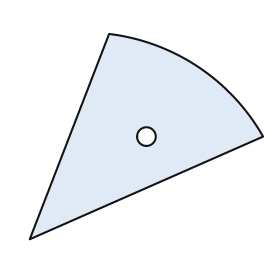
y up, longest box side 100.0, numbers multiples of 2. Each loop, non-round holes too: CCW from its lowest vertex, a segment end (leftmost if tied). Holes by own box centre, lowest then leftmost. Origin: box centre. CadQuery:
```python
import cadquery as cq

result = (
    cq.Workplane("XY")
    .moveTo(-50.0, -44.0)
    .lineTo(50.0, 0.0)
    .threePointArc((22.0, 30.0), (-16.0, 44.0))
    .close()
    .moveTo(0.0, 0.0)
    .circle(4.0)
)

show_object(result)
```